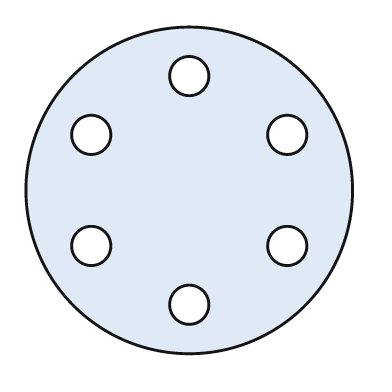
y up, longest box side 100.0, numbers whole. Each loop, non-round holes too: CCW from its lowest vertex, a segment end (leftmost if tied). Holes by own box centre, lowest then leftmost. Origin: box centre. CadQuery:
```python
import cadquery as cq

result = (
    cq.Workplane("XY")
    .moveTo(0.0, 0.0)
    .circle(50.0)
    .moveTo(0.0, -35.0)
    .circle(6.0)
    .moveTo(-30.0, -17.0)
    .circle(6.0)
    .moveTo(30.0, -17.0)
    .circle(6.0)
    .moveTo(-30.0, 17.0)
    .circle(6.0)
    .moveTo(30.0, 17.0)
    .circle(6.0)
    .moveTo(0.0, 35.0)
    .circle(6.0)
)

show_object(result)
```